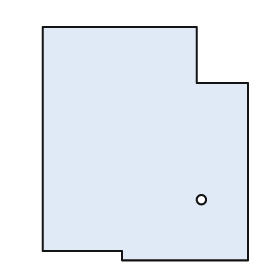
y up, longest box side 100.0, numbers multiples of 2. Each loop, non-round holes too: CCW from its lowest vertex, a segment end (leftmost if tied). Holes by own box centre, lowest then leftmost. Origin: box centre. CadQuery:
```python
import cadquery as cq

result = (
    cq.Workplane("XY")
    .moveTo(-10.0, -50.0)
    .lineTo(44.0, -50.0)
    .lineTo(44.0, 26.0)
    .lineTo(22.0, 26.0)
    .lineTo(22.0, 50.0)
    .lineTo(-44.0, 50.0)
    .lineTo(-44.0, -46.0)
    .lineTo(-10.0, -46.0)
    .close()
    .moveTo(24.0, -24.0)
    .circle(2.0)
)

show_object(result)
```